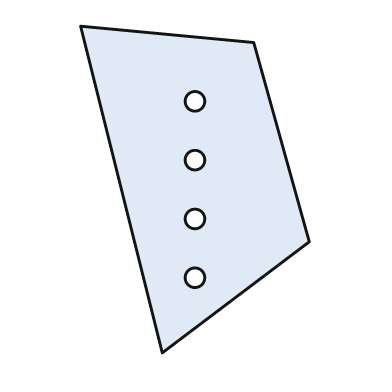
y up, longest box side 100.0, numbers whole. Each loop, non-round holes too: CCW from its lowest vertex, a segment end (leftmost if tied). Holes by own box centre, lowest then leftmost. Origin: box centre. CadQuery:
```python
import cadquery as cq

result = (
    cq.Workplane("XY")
    .moveTo(-10.0, -50.0)
    .lineTo(35.0, -16.0)
    .lineTo(18.0, 45.0)
    .lineTo(-35.0, 50.0)
    .close()
    .moveTo(0.0, -27.0)
    .circle(3.0)
    .moveTo(0.0, -9.0)
    .circle(3.0)
    .moveTo(0.0, 9.0)
    .circle(3.0)
    .moveTo(0.0, 27.0)
    .circle(3.0)
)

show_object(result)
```